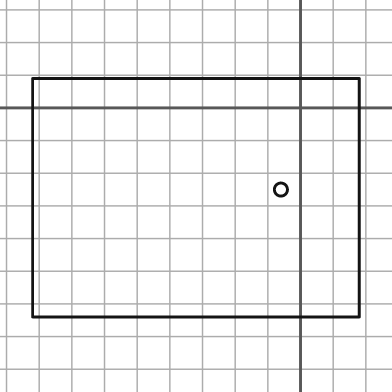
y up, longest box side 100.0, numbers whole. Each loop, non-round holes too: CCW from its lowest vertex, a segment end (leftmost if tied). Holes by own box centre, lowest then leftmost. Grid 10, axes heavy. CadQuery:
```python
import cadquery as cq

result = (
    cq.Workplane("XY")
    .moveTo(-82.0, -64.0)
    .lineTo(18.0, -64.0)
    .lineTo(18.0, 9.0)
    .lineTo(-82.0, 9.0)
    .close()
    .moveTo(-6.0, -25.0)
    .circle(2.0)
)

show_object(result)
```